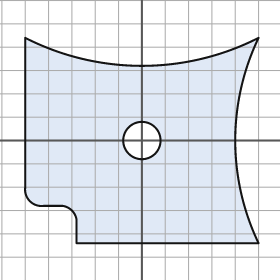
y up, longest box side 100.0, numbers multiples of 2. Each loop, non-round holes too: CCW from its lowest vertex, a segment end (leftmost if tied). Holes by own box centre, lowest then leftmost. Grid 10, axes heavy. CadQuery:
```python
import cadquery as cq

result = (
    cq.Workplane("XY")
    .moveTo(-28.0, -44.0)
    .lineTo(50.0, -44.0)
    .threePointArc((40.0, 0.0), (50.0, 44.0))
    .threePointArc((0.0, 32.0), (-50.0, 44.0))
    .lineTo(-50.0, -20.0)
    .threePointArc((-48.0, -26.0), (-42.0, -28.0))
    .lineTo(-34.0, -28.0)
    .threePointArc((-30.0, -30.0), (-28.0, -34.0))
    .close()
    .moveTo(0.0, 0.0)
    .circle(8.0)
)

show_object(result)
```